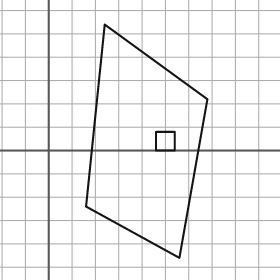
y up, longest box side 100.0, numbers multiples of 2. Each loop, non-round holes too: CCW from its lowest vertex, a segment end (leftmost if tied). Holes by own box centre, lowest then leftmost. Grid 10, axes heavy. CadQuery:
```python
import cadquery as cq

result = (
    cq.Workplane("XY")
    .moveTo(56.0, -46.0)
    .lineTo(68.0, 22.0)
    .lineTo(24.0, 54.0)
    .lineTo(16.0, -24.0)
    .close()
    .moveTo(46.0, 0.0)
    .lineTo(54.0, 0.0)
    .lineTo(54.0, 8.0)
    .lineTo(46.0, 8.0)
    .close()
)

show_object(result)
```